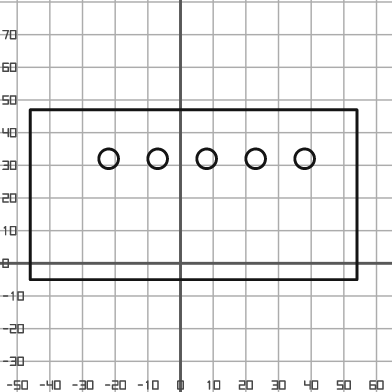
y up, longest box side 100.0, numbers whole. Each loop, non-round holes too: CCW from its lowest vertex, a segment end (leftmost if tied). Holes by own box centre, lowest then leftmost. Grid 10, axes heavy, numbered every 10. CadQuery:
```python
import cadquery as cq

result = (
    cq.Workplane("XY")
    .moveTo(-46.0, -5.0)
    .lineTo(54.0, -5.0)
    .lineTo(54.0, 47.0)
    .lineTo(-46.0, 47.0)
    .close()
    .moveTo(-22.0, 32.0)
    .circle(3.0)
    .moveTo(-7.0, 32.0)
    .circle(3.0)
    .moveTo(8.0, 32.0)
    .circle(3.0)
    .moveTo(23.0, 32.0)
    .circle(3.0)
    .moveTo(38.0, 32.0)
    .circle(3.0)
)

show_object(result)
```